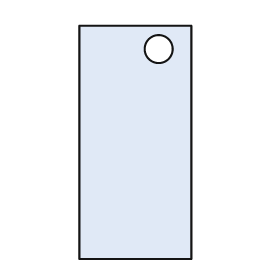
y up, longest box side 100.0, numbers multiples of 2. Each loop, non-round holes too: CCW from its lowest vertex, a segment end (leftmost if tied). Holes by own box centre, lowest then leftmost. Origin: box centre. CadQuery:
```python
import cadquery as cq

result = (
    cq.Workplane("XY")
    .moveTo(-24.0, -50.0)
    .lineTo(24.0, -50.0)
    .lineTo(24.0, 50.0)
    .lineTo(-24.0, 50.0)
    .close()
    .moveTo(10.0, 40.0)
    .circle(6.0)
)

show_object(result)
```